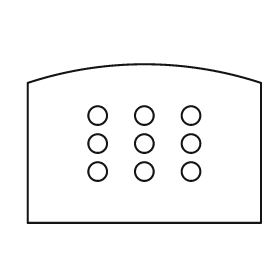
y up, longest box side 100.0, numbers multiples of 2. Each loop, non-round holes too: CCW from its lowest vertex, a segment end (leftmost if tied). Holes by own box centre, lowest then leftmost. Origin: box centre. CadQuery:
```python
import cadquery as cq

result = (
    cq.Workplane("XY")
    .moveTo(-50.0, -34.0)
    .lineTo(50.0, -34.0)
    .lineTo(50.0, 26.0)
    .threePointArc((0.0, 34.0), (-50.0, 26.0))
    .close()
    .moveTo(-20.0, -12.0)
    .circle(4.0)
    .moveTo(0.0, -12.0)
    .circle(4.0)
    .moveTo(20.0, -12.0)
    .circle(4.0)
    .moveTo(-20.0, 0.0)
    .circle(4.0)
    .moveTo(0.0, 0.0)
    .circle(4.0)
    .moveTo(20.0, 0.0)
    .circle(4.0)
    .moveTo(-20.0, 12.0)
    .circle(4.0)
    .moveTo(0.0, 12.0)
    .circle(4.0)
    .moveTo(20.0, 12.0)
    .circle(4.0)
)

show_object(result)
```